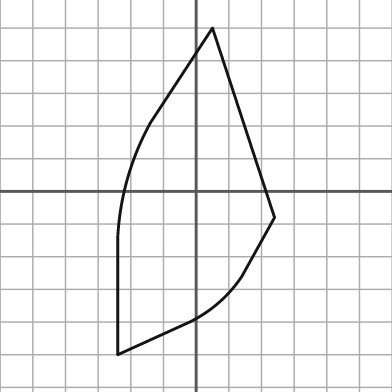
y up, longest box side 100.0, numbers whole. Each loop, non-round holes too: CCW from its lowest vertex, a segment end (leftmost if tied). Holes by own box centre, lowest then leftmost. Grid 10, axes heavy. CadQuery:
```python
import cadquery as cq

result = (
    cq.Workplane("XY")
    .moveTo(-24.0, -50.0)
    .lineTo(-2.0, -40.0)
    .threePointArc((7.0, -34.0), (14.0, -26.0))
    .lineTo(24.0, -8.0)
    .lineTo(5.0, 50.0)
    .lineTo(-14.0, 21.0)
    .threePointArc((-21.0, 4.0), (-24.0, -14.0))
    .close()
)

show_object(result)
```